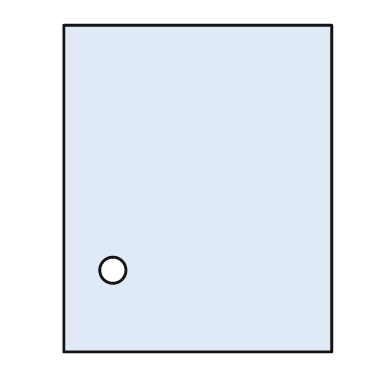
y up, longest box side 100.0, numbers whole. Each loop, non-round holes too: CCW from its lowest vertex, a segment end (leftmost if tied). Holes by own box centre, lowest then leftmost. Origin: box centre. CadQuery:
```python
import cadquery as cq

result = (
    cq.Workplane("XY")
    .moveTo(-41.0, -50.0)
    .lineTo(41.0, -50.0)
    .lineTo(41.0, 50.0)
    .lineTo(-41.0, 50.0)
    .close()
    .moveTo(-26.0, -25.0)
    .circle(4.0)
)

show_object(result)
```